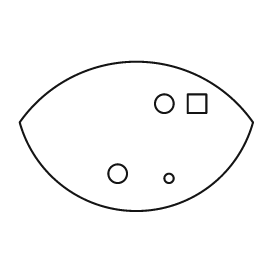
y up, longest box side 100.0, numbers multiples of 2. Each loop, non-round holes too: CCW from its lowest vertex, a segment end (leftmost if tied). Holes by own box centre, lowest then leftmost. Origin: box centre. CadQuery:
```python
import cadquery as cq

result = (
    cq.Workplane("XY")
    .moveTo(-50.0, 6.0)
    .threePointArc((0.0, -32.0), (50.0, 6.0))
    .threePointArc((0.0, 32.0), (-50.0, 6.0))
    .close()
    .moveTo(14.0, -18.0)
    .circle(2.0)
    .moveTo(-8.0, -16.0)
    .circle(4.0)
    .moveTo(12.0, 14.0)
    .circle(4.0)
    .moveTo(22.0, 10.0)
    .lineTo(30.0, 10.0)
    .lineTo(30.0, 18.0)
    .lineTo(22.0, 18.0)
    .close()
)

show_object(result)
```